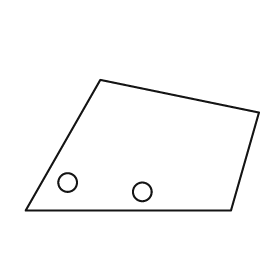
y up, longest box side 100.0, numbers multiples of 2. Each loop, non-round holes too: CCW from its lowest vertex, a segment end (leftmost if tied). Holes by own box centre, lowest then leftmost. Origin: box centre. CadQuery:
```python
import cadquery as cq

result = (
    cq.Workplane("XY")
    .moveTo(-50.0, -28.0)
    .lineTo(38.0, -28.0)
    .lineTo(50.0, 14.0)
    .lineTo(-18.0, 28.0)
    .close()
    .moveTo(0.0, -20.0)
    .circle(4.0)
    .moveTo(-32.0, -16.0)
    .circle(4.0)
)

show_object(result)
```